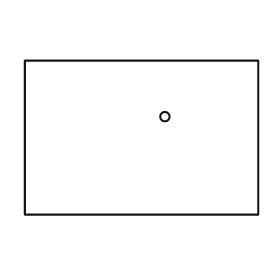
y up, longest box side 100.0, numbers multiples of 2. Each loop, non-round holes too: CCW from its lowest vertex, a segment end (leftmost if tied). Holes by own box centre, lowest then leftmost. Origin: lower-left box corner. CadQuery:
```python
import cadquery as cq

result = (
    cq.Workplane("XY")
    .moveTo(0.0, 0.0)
    .lineTo(100.0, 0.0)
    .lineTo(100.0, 66.0)
    .lineTo(0.0, 66.0)
    .close()
    .moveTo(60.0, 42.0)
    .circle(2.0)
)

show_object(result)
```